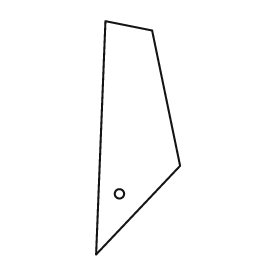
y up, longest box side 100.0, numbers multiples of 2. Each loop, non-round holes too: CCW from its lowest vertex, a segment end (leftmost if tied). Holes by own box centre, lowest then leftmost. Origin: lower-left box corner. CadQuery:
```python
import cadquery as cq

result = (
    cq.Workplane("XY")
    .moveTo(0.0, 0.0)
    .lineTo(36.0, 38.0)
    .lineTo(24.0, 96.0)
    .lineTo(4.0, 100.0)
    .close()
    .moveTo(10.0, 26.0)
    .circle(2.0)
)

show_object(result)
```